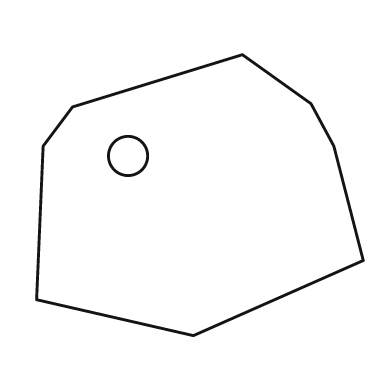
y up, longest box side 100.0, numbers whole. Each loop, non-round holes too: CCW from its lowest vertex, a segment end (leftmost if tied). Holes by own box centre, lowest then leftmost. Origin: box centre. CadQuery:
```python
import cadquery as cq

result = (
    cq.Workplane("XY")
    .moveTo(-2.0, -43.0)
    .lineTo(50.0, -20.0)
    .lineTo(41.0, 15.0)
    .lineTo(34.0, 28.0)
    .lineTo(13.0, 43.0)
    .lineTo(-39.0, 27.0)
    .lineTo(-48.0, 15.0)
    .lineTo(-50.0, -32.0)
    .close()
    .moveTo(-22.0, 12.0)
    .circle(6.0)
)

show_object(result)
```